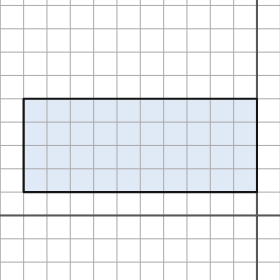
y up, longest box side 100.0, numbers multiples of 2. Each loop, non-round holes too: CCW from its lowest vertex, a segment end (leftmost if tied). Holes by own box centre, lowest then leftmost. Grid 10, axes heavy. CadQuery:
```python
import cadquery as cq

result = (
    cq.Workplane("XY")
    .moveTo(-100.0, 10.0)
    .lineTo(0.0, 10.0)
    .lineTo(0.0, 50.0)
    .lineTo(-100.0, 50.0)
    .close()
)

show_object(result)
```